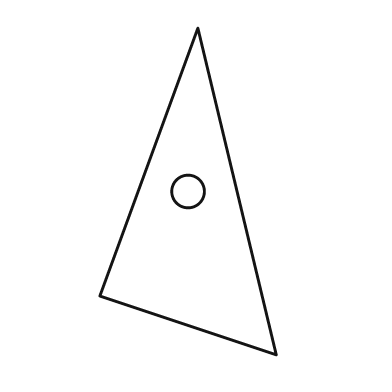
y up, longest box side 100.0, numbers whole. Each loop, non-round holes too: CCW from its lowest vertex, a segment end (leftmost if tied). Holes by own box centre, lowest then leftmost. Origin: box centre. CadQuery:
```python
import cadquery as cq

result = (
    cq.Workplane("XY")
    .moveTo(27.0, -50.0)
    .lineTo(3.0, 50.0)
    .lineTo(-27.0, -32.0)
    .close()
    .moveTo(0.0, 0.0)
    .circle(5.0)
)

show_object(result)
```